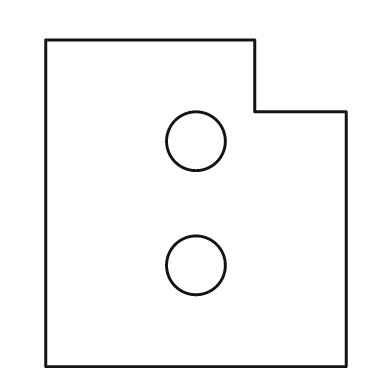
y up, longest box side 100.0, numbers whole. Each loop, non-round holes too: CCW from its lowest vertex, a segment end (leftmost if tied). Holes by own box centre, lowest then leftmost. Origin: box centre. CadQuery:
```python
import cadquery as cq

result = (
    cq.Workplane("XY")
    .moveTo(-46.0, -50.0)
    .lineTo(46.0, -50.0)
    .lineTo(46.0, 28.0)
    .lineTo(18.0, 28.0)
    .lineTo(18.0, 50.0)
    .lineTo(-46.0, 50.0)
    .close()
    .moveTo(0.0, -19.0)
    .circle(9.0)
    .moveTo(0.0, 19.0)
    .circle(9.0)
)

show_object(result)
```